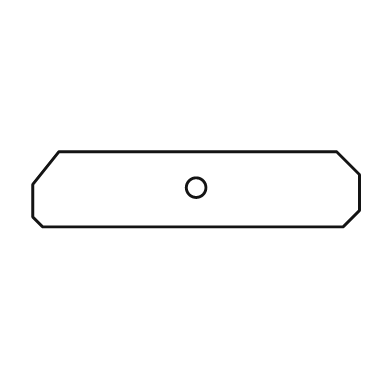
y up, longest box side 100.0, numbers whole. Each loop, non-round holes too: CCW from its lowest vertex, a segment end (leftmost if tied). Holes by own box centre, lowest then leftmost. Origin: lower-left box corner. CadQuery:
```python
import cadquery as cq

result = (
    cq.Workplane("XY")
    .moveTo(3.0, 0.0)
    .lineTo(95.0, 0.0)
    .lineTo(100.0, 5.0)
    .lineTo(100.0, 16.0)
    .lineTo(93.0, 23.0)
    .lineTo(8.0, 23.0)
    .lineTo(0.0, 13.0)
    .lineTo(0.0, 3.0)
    .close()
    .moveTo(50.0, 12.0)
    .circle(3.0)
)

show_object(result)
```